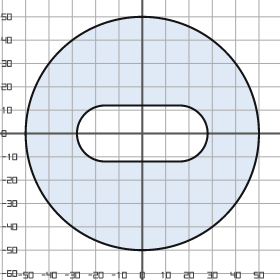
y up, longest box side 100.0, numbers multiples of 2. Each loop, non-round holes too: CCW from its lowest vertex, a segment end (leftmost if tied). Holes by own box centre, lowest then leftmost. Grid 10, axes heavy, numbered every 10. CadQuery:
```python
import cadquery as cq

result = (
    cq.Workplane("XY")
    .moveTo(0.0, 0.0)
    .circle(50.0)
    .moveTo(-16.0, -12.0)
    .lineTo(16.0, -12.0)
    .threePointArc((28.0, 0.0), (16.0, 12.0))
    .lineTo(-16.0, 12.0)
    .threePointArc((-28.0, 0.0), (-16.0, -12.0))
    .close()
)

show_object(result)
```